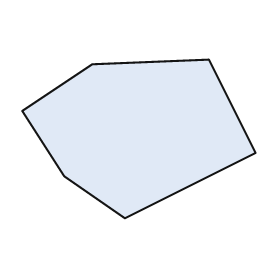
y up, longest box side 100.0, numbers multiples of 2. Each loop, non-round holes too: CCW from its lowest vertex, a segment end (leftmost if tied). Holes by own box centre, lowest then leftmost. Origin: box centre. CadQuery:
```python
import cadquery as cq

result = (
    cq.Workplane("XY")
    .moveTo(-6.0, -34.0)
    .lineTo(50.0, -6.0)
    .lineTo(30.0, 34.0)
    .lineTo(-20.0, 32.0)
    .lineTo(-50.0, 12.0)
    .lineTo(-32.0, -16.0)
    .close()
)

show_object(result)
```